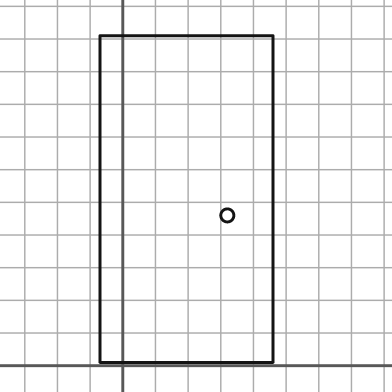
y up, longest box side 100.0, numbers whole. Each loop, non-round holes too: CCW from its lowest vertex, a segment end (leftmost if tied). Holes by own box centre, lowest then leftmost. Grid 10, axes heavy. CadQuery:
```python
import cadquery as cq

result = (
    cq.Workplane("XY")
    .moveTo(-7.0, 1.0)
    .lineTo(46.0, 1.0)
    .lineTo(46.0, 101.0)
    .lineTo(-7.0, 101.0)
    .close()
    .moveTo(32.0, 46.0)
    .circle(2.0)
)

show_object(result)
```